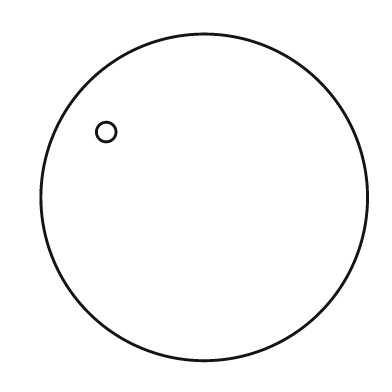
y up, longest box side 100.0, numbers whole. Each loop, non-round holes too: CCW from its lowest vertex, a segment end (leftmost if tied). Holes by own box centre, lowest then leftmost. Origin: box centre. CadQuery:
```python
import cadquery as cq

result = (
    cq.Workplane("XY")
    .moveTo(0.0, 0.0)
    .circle(50.0)
    .moveTo(-30.0, 20.0)
    .circle(3.0)
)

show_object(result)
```